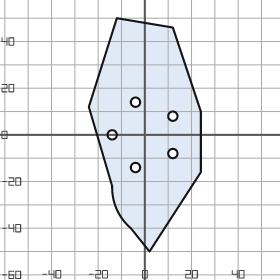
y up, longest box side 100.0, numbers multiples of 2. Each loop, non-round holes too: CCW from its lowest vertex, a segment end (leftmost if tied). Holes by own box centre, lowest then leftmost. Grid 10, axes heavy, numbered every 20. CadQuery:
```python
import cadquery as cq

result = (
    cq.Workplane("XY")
    .moveTo(2.0, -50.0)
    .lineTo(24.0, -16.0)
    .lineTo(24.0, 10.0)
    .lineTo(12.0, 46.0)
    .lineTo(-12.0, 50.0)
    .lineTo(-24.0, 12.0)
    .lineTo(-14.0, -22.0)
    .threePointArc((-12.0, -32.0), (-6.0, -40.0))
    .close()
    .moveTo(-4.0, -14.0)
    .circle(2.0)
    .moveTo(12.0, -8.0)
    .circle(2.0)
    .moveTo(-14.0, 0.0)
    .circle(2.0)
    .moveTo(12.0, 8.0)
    .circle(2.0)
    .moveTo(-4.0, 14.0)
    .circle(2.0)
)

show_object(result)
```